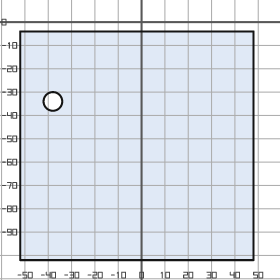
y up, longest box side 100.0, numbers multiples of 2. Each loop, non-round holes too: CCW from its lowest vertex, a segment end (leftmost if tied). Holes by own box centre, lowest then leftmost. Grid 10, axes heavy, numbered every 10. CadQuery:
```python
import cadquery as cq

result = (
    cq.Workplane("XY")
    .moveTo(-52.0, -102.0)
    .lineTo(48.0, -102.0)
    .lineTo(48.0, -4.0)
    .lineTo(-52.0, -4.0)
    .close()
    .moveTo(-38.0, -34.0)
    .circle(4.0)
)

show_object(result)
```